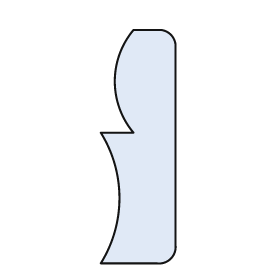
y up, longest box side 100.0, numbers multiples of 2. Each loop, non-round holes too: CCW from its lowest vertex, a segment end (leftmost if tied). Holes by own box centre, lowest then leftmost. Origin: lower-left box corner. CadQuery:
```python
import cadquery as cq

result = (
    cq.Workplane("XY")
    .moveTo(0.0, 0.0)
    .lineTo(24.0, 0.0)
    .threePointArc((30.0, 2.0), (32.0, 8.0))
    .lineTo(32.0, 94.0)
    .threePointArc((30.0, 98.0), (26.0, 100.0))
    .lineTo(14.0, 100.0)
    .threePointArc((6.0, 78.0), (14.0, 56.0))
    .lineTo(0.0, 56.0)
    .threePointArc((8.0, 28.0), (0.0, 0.0))
    .close()
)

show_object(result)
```